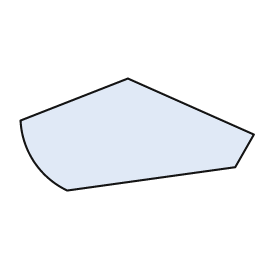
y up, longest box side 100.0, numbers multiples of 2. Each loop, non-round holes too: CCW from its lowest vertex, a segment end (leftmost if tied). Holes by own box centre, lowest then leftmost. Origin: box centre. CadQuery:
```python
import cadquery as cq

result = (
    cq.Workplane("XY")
    .moveTo(-30.0, -24.0)
    .lineTo(42.0, -14.0)
    .lineTo(50.0, 0.0)
    .lineTo(-4.0, 24.0)
    .lineTo(-50.0, 6.0)
    .threePointArc((-44.0, -12.0), (-30.0, -24.0))
    .close()
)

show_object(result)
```